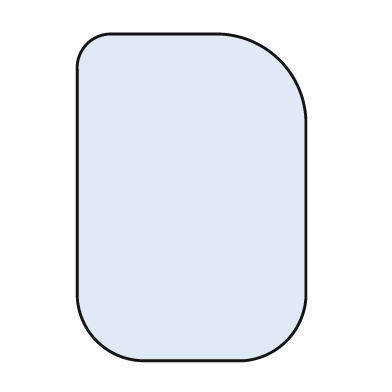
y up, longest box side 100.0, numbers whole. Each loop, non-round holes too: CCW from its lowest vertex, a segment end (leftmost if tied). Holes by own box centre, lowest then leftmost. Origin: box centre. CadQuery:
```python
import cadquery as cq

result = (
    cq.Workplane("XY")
    .moveTo(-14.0, -50.0)
    .lineTo(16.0, -50.0)
    .threePointArc((29.0, -44.0), (35.0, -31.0))
    .lineTo(35.0, 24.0)
    .threePointArc((27.0, 42.0), (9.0, 50.0))
    .lineTo(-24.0, 50.0)
    .threePointArc((-32.0, 47.0), (-35.0, 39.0))
    .lineTo(-35.0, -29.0)
    .threePointArc((-29.0, -44.0), (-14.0, -50.0))
    .close()
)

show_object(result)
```